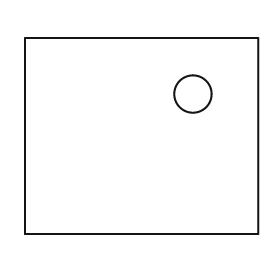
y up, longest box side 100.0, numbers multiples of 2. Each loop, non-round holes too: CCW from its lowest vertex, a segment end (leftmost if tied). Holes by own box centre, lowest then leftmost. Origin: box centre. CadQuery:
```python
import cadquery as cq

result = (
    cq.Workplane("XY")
    .moveTo(-50.0, -42.0)
    .lineTo(50.0, -42.0)
    .lineTo(50.0, 42.0)
    .lineTo(-50.0, 42.0)
    .close()
    .moveTo(22.0, 18.0)
    .circle(8.0)
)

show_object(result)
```